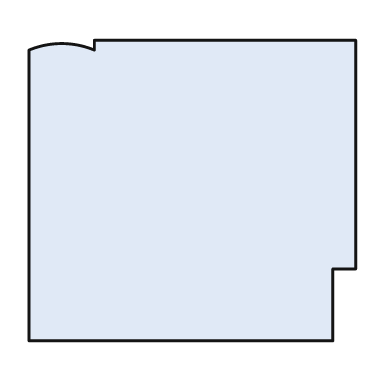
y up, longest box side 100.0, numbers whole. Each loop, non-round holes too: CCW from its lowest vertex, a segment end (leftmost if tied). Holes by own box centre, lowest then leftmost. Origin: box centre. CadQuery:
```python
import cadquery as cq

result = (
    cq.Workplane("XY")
    .moveTo(-50.0, -46.0)
    .lineTo(43.0, -46.0)
    .lineTo(43.0, -24.0)
    .lineTo(50.0, -24.0)
    .lineTo(50.0, 46.0)
    .lineTo(-30.0, 46.0)
    .lineTo(-30.0, 43.0)
    .threePointArc((-40.0, 45.0), (-50.0, 43.0))
    .close()
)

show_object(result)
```